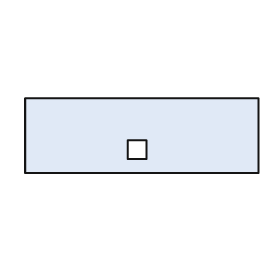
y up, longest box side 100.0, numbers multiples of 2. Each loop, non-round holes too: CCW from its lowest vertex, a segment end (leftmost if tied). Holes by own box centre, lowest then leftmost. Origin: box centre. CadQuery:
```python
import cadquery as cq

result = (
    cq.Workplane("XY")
    .moveTo(-50.0, -16.0)
    .lineTo(50.0, -16.0)
    .lineTo(50.0, 16.0)
    .lineTo(-50.0, 16.0)
    .close()
    .moveTo(-6.0, -10.0)
    .lineTo(2.0, -10.0)
    .lineTo(2.0, -2.0)
    .lineTo(-6.0, -2.0)
    .close()
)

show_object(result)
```